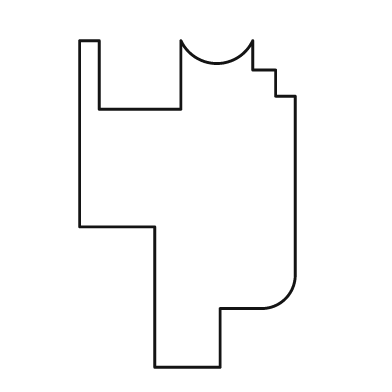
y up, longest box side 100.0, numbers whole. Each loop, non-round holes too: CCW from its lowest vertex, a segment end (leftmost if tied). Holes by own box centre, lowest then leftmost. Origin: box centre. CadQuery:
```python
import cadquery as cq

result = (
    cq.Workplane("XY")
    .moveTo(-10.0, -50.0)
    .lineTo(10.0, -50.0)
    .lineTo(10.0, -32.0)
    .lineTo(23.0, -32.0)
    .threePointArc((30.0, -29.0), (33.0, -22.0))
    .lineTo(33.0, 33.0)
    .lineTo(27.0, 33.0)
    .lineTo(27.0, 41.0)
    .lineTo(20.0, 41.0)
    .lineTo(20.0, 50.0)
    .threePointArc((9.0, 43.0), (-2.0, 50.0))
    .lineTo(-2.0, 29.0)
    .lineTo(-27.0, 29.0)
    .lineTo(-27.0, 50.0)
    .lineTo(-33.0, 50.0)
    .lineTo(-33.0, -7.0)
    .lineTo(-10.0, -7.0)
    .close()
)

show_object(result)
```